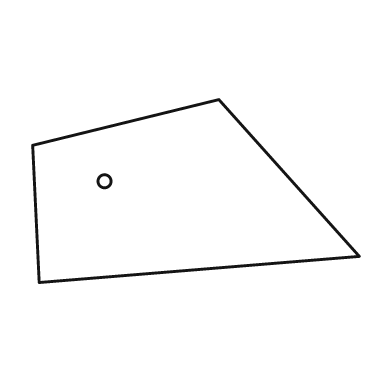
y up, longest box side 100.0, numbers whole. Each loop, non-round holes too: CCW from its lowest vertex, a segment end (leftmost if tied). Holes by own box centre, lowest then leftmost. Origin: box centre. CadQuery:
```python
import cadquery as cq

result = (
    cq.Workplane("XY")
    .moveTo(-48.0, -28.0)
    .lineTo(50.0, -20.0)
    .lineTo(7.0, 28.0)
    .lineTo(-50.0, 14.0)
    .close()
    .moveTo(-28.0, 3.0)
    .circle(2.0)
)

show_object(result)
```